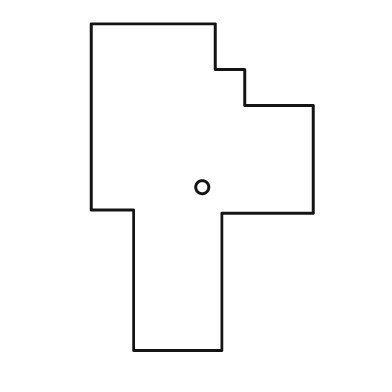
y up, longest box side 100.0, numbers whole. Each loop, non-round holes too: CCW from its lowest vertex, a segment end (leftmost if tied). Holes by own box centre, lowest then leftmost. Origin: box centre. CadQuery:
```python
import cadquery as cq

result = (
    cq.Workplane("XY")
    .moveTo(-21.0, -50.0)
    .lineTo(6.0, -50.0)
    .lineTo(6.0, -8.0)
    .lineTo(34.0, -8.0)
    .lineTo(34.0, 25.0)
    .lineTo(13.0, 25.0)
    .lineTo(13.0, 36.0)
    .lineTo(4.0, 36.0)
    .lineTo(4.0, 50.0)
    .lineTo(-34.0, 50.0)
    .lineTo(-34.0, -7.0)
    .lineTo(-21.0, -7.0)
    .close()
    .moveTo(0.0, 0.0)
    .circle(2.0)
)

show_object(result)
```